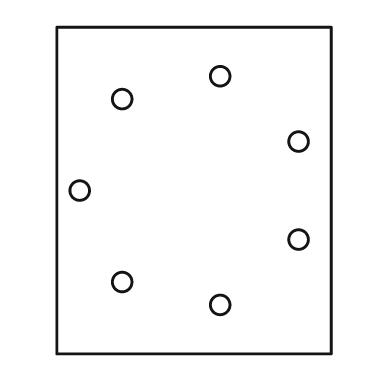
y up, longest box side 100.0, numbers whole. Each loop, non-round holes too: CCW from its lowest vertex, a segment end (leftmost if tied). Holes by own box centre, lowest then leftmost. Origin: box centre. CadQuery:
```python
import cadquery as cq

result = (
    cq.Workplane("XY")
    .moveTo(-42.0, -50.0)
    .lineTo(42.0, -50.0)
    .lineTo(42.0, 50.0)
    .lineTo(-42.0, 50.0)
    .close()
    .moveTo(8.0, -35.0)
    .circle(3.0)
    .moveTo(-22.0, -28.0)
    .circle(3.0)
    .moveTo(32.0, -15.0)
    .circle(3.0)
    .moveTo(-35.0, 0.0)
    .circle(3.0)
    .moveTo(32.0, 15.0)
    .circle(3.0)
    .moveTo(-22.0, 28.0)
    .circle(3.0)
    .moveTo(8.0, 35.0)
    .circle(3.0)
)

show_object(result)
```